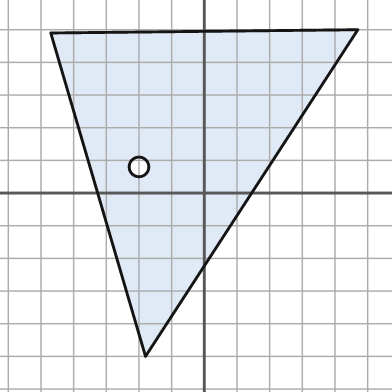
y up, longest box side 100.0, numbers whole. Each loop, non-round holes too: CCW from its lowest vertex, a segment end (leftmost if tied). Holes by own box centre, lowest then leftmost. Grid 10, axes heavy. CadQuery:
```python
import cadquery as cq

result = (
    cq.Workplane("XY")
    .moveTo(-18.0, -50.0)
    .lineTo(47.0, 50.0)
    .lineTo(-47.0, 49.0)
    .close()
    .moveTo(-20.0, 8.0)
    .circle(3.0)
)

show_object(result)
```